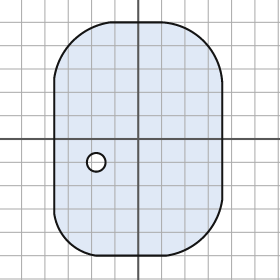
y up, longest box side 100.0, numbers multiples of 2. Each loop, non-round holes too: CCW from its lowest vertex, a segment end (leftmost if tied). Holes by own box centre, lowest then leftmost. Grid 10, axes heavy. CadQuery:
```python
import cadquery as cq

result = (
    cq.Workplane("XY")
    .moveTo(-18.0, -50.0)
    .lineTo(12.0, -50.0)
    .threePointArc((28.0, -42.0), (36.0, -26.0))
    .lineTo(36.0, 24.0)
    .threePointArc((28.0, 42.0), (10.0, 50.0))
    .lineTo(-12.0, 50.0)
    .threePointArc((-28.0, 42.0), (-36.0, 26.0))
    .lineTo(-36.0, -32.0)
    .threePointArc((-30.0, -44.0), (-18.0, -50.0))
    .close()
    .moveTo(-18.0, -10.0)
    .circle(4.0)
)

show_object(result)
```